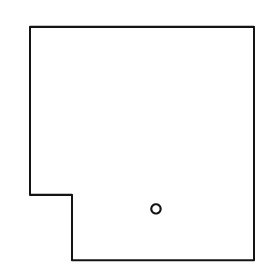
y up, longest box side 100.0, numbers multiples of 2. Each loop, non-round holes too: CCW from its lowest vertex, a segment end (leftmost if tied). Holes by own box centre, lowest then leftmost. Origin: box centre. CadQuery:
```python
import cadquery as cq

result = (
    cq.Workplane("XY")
    .moveTo(-30.0, -50.0)
    .lineTo(48.0, -50.0)
    .lineTo(48.0, 50.0)
    .lineTo(-48.0, 50.0)
    .lineTo(-48.0, -22.0)
    .lineTo(-30.0, -22.0)
    .close()
    .moveTo(6.0, -28.0)
    .circle(2.0)
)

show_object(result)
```